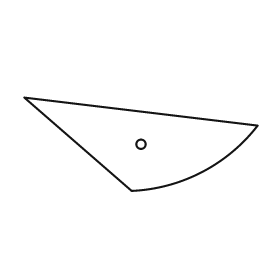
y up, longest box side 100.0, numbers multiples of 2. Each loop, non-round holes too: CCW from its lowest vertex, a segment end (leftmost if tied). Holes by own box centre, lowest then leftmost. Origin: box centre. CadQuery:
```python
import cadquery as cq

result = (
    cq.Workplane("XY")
    .moveTo(-4.0, -20.0)
    .threePointArc((26.0, -12.0), (50.0, 8.0))
    .lineTo(-50.0, 20.0)
    .close()
    .moveTo(0.0, 0.0)
    .circle(2.0)
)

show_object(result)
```